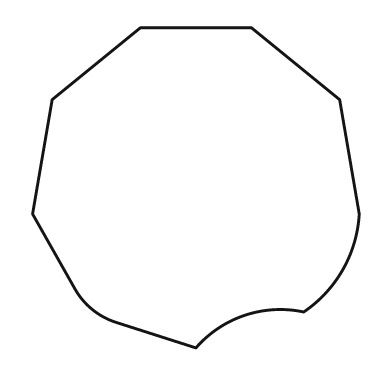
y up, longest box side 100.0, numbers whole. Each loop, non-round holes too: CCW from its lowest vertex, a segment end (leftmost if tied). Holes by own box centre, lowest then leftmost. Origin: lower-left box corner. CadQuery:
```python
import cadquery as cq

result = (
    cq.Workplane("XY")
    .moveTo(50.0, 0.0)
    .threePointArc((65.0, 10.0), (83.0, 11.0))
    .threePointArc((95.0, 24.0), (100.0, 41.0))
    .lineTo(94.0, 76.0)
    .lineTo(67.0, 98.0)
    .lineTo(33.0, 98.0)
    .lineTo(6.0, 76.0)
    .lineTo(0.0, 41.0)
    .lineTo(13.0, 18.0)
    .threePointArc((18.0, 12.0), (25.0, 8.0))
    .close()
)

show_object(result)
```